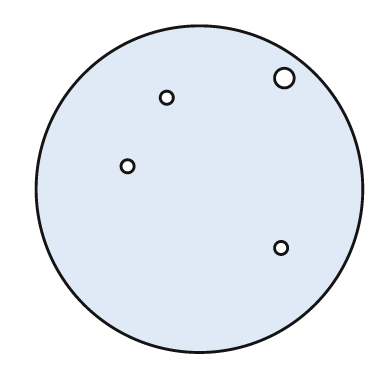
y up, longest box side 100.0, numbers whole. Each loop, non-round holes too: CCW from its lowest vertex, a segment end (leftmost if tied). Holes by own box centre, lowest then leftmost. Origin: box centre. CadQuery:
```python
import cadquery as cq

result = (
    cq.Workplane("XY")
    .moveTo(0.0, 0.0)
    .circle(50.0)
    .moveTo(25.0, -18.0)
    .circle(2.0)
    .moveTo(-22.0, 7.0)
    .circle(2.0)
    .moveTo(-10.0, 28.0)
    .circle(2.0)
    .moveTo(26.0, 34.0)
    .circle(3.0)
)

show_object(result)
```